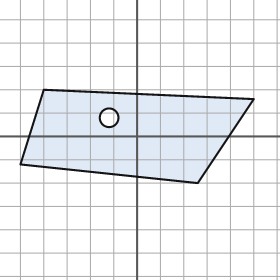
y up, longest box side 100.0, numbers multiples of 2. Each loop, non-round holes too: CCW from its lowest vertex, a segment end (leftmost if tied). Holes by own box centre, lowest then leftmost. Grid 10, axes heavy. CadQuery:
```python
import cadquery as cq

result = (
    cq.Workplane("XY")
    .moveTo(26.0, -20.0)
    .lineTo(50.0, 16.0)
    .lineTo(-40.0, 20.0)
    .lineTo(-50.0, -12.0)
    .close()
    .moveTo(-12.0, 8.0)
    .circle(4.0)
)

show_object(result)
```